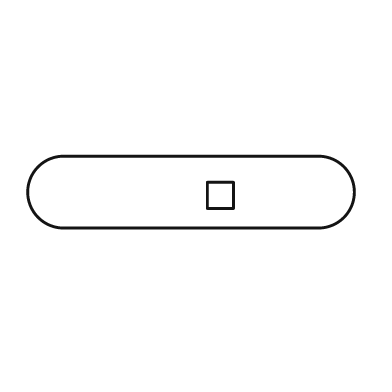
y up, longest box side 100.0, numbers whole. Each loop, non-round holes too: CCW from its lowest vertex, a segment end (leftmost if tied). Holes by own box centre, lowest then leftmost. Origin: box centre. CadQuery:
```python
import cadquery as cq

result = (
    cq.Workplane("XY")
    .moveTo(-39.0, -11.0)
    .lineTo(39.0, -11.0)
    .threePointArc((50.0, 0.0), (39.0, 11.0))
    .lineTo(-39.0, 11.0)
    .threePointArc((-50.0, 0.0), (-39.0, -11.0))
    .close()
    .moveTo(5.0, -5.0)
    .lineTo(13.0, -5.0)
    .lineTo(13.0, 3.0)
    .lineTo(5.0, 3.0)
    .close()
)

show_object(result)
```